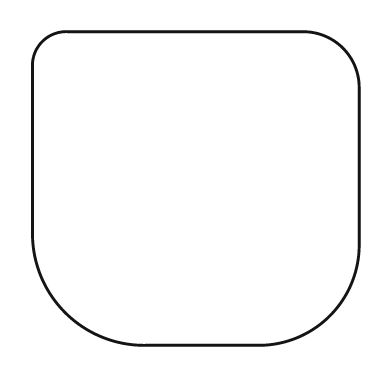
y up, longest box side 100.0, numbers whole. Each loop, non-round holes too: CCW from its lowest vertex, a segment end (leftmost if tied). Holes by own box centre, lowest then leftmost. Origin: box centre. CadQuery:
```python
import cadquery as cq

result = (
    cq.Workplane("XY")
    .moveTo(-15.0, -48.0)
    .lineTo(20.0, -48.0)
    .threePointArc((41.0, -39.0), (50.0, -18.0))
    .lineTo(50.0, 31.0)
    .threePointArc((45.0, 43.0), (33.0, 48.0))
    .lineTo(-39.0, 48.0)
    .threePointArc((-47.0, 45.0), (-50.0, 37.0))
    .lineTo(-50.0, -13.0)
    .threePointArc((-40.0, -38.0), (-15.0, -48.0))
    .close()
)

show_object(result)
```